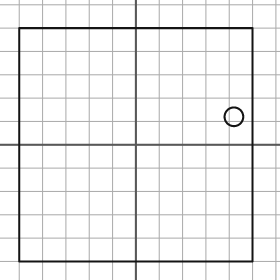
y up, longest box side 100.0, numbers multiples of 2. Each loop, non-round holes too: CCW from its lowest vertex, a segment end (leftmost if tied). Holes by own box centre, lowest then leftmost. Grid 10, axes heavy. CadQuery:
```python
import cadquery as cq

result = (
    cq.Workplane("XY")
    .moveTo(-50.0, -50.0)
    .lineTo(50.0, -50.0)
    .lineTo(50.0, 50.0)
    .lineTo(-50.0, 50.0)
    .close()
    .moveTo(42.0, 12.0)
    .circle(4.0)
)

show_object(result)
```